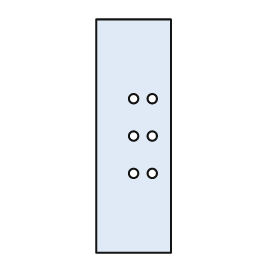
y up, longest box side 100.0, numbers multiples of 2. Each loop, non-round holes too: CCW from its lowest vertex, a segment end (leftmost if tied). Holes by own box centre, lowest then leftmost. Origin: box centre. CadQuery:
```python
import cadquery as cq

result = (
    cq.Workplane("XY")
    .moveTo(-16.0, -50.0)
    .lineTo(16.0, -50.0)
    .lineTo(16.0, 50.0)
    .lineTo(-16.0, 50.0)
    .close()
    .moveTo(0.0, -16.0)
    .circle(2.0)
    .moveTo(8.0, -16.0)
    .circle(2.0)
    .moveTo(0.0, 0.0)
    .circle(2.0)
    .moveTo(8.0, 0.0)
    .circle(2.0)
    .moveTo(0.0, 16.0)
    .circle(2.0)
    .moveTo(8.0, 16.0)
    .circle(2.0)
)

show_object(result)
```